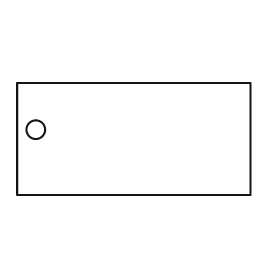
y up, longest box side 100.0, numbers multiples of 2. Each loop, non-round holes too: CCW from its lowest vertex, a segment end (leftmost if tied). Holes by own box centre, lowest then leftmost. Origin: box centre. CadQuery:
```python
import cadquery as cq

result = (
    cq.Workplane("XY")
    .moveTo(-50.0, -24.0)
    .lineTo(50.0, -24.0)
    .lineTo(50.0, 24.0)
    .lineTo(-50.0, 24.0)
    .close()
    .moveTo(-42.0, 4.0)
    .circle(4.0)
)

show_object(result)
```